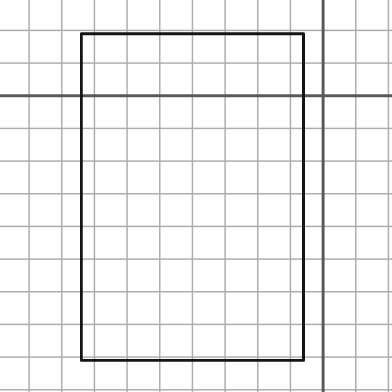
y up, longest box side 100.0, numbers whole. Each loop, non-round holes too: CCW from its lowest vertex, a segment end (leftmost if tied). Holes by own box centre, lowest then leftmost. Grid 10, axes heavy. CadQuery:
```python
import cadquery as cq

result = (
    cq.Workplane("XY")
    .moveTo(-74.0, -81.0)
    .lineTo(-6.0, -81.0)
    .lineTo(-6.0, 19.0)
    .lineTo(-74.0, 19.0)
    .close()
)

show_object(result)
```